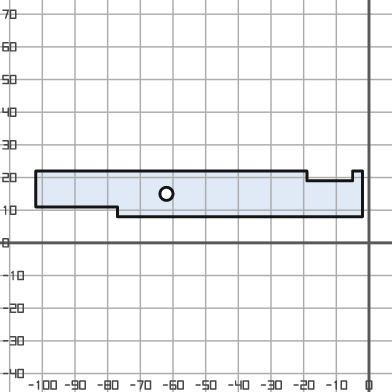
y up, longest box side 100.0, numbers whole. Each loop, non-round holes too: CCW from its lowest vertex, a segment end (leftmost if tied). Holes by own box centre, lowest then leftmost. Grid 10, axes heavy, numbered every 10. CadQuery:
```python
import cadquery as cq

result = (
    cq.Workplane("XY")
    .moveTo(-77.0, 8.0)
    .lineTo(-2.0, 8.0)
    .lineTo(-2.0, 22.0)
    .lineTo(-5.0, 22.0)
    .lineTo(-5.0, 19.0)
    .lineTo(-19.0, 19.0)
    .lineTo(-19.0, 22.0)
    .lineTo(-102.0, 22.0)
    .lineTo(-102.0, 11.0)
    .lineTo(-77.0, 11.0)
    .close()
    .moveTo(-62.0, 15.0)
    .circle(2.0)
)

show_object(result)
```